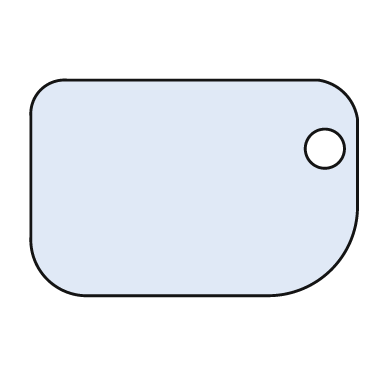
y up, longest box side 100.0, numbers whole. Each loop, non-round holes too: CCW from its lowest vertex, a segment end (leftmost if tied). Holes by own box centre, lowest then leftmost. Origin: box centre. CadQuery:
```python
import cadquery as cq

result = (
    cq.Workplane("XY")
    .moveTo(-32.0, -33.0)
    .lineTo(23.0, -33.0)
    .threePointArc((42.0, -25.0), (50.0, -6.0))
    .lineTo(50.0, 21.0)
    .threePointArc((46.0, 29.0), (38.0, 33.0))
    .lineTo(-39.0, 33.0)
    .threePointArc((-47.0, 30.0), (-50.0, 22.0))
    .lineTo(-50.0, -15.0)
    .threePointArc((-45.0, -28.0), (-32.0, -33.0))
    .close()
    .moveTo(40.0, 12.0)
    .circle(6.0)
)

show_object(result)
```